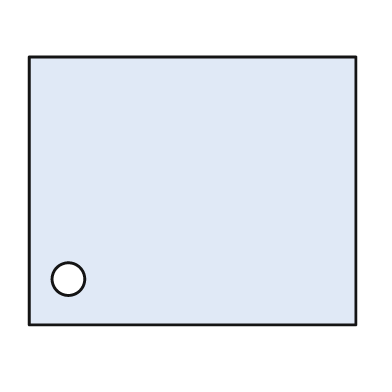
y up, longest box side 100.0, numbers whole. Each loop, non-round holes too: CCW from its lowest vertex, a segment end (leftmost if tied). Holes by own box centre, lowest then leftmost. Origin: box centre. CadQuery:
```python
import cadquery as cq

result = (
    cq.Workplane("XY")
    .moveTo(-50.0, -41.0)
    .lineTo(50.0, -41.0)
    .lineTo(50.0, 41.0)
    .lineTo(-50.0, 41.0)
    .close()
    .moveTo(-38.0, -27.0)
    .circle(5.0)
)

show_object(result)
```